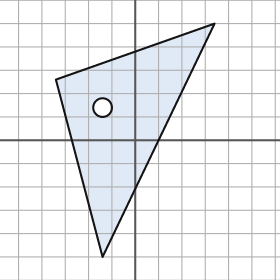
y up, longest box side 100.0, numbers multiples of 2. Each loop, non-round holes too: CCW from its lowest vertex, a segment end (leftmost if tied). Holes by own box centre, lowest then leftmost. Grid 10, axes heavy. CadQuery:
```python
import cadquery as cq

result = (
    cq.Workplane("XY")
    .moveTo(-14.0, -50.0)
    .lineTo(34.0, 50.0)
    .lineTo(-34.0, 26.0)
    .close()
    .moveTo(-14.0, 14.0)
    .circle(4.0)
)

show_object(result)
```